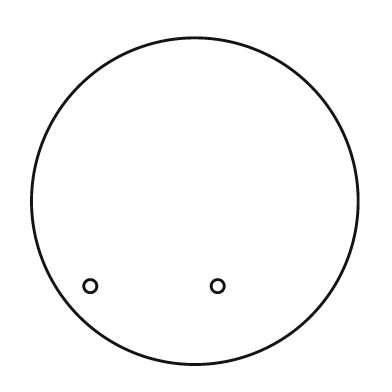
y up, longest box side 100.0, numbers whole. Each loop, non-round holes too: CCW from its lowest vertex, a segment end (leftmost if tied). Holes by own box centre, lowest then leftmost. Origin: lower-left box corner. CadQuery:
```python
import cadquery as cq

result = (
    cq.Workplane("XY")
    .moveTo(50.0, 50.0)
    .circle(50.0)
    .moveTo(18.0, 24.0)
    .circle(2.0)
    .moveTo(57.0, 24.0)
    .circle(2.0)
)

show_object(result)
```